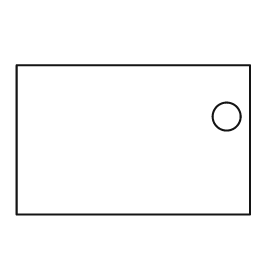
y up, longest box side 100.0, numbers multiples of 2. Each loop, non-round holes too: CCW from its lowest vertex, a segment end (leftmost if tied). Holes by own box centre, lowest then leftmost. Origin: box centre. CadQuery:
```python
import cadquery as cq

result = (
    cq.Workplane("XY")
    .moveTo(-50.0, -32.0)
    .lineTo(50.0, -32.0)
    .lineTo(50.0, 32.0)
    .lineTo(-50.0, 32.0)
    .close()
    .moveTo(40.0, 10.0)
    .circle(6.0)
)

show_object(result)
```